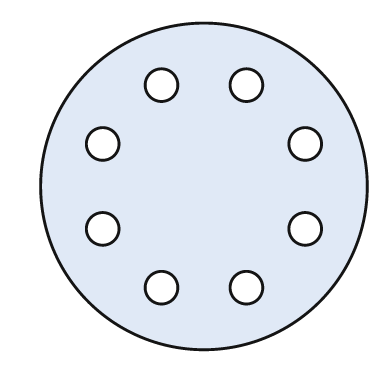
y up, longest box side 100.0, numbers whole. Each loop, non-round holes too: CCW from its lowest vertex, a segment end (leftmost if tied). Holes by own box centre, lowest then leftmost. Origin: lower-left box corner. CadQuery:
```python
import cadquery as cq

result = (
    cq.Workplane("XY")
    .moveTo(50.0, 50.0)
    .circle(50.0)
    .moveTo(37.0, 19.0)
    .circle(5.0)
    .moveTo(63.0, 19.0)
    .circle(5.0)
    .moveTo(19.0, 37.0)
    .circle(5.0)
    .moveTo(81.0, 37.0)
    .circle(5.0)
    .moveTo(19.0, 63.0)
    .circle(5.0)
    .moveTo(81.0, 63.0)
    .circle(5.0)
    .moveTo(37.0, 81.0)
    .circle(5.0)
    .moveTo(63.0, 81.0)
    .circle(5.0)
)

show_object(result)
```